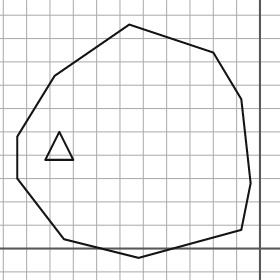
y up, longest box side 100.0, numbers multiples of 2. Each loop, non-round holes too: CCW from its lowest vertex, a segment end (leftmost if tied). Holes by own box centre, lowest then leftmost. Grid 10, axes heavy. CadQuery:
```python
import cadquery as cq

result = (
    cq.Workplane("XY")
    .moveTo(-52.0, -4.0)
    .lineTo(-8.0, 8.0)
    .lineTo(-4.0, 28.0)
    .lineTo(-8.0, 64.0)
    .lineTo(-20.0, 84.0)
    .lineTo(-56.0, 96.0)
    .lineTo(-88.0, 74.0)
    .lineTo(-104.0, 48.0)
    .lineTo(-104.0, 30.0)
    .lineTo(-84.0, 4.0)
    .close()
    .moveTo(-92.0, 38.0)
    .lineTo(-80.0, 38.0)
    .lineTo(-86.0, 50.0)
    .close()
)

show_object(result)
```